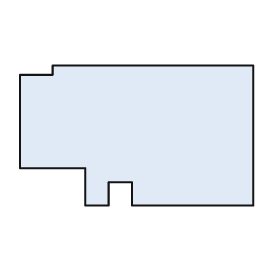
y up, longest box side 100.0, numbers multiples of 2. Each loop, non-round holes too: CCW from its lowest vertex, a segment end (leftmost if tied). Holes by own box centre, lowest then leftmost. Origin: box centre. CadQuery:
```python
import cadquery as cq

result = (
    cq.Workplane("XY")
    .moveTo(-22.0, -30.0)
    .lineTo(-12.0, -30.0)
    .lineTo(-12.0, -20.0)
    .lineTo(-2.0, -20.0)
    .lineTo(-2.0, -30.0)
    .lineTo(50.0, -30.0)
    .lineTo(50.0, 30.0)
    .lineTo(-36.0, 30.0)
    .lineTo(-36.0, 26.0)
    .lineTo(-50.0, 26.0)
    .lineTo(-50.0, -14.0)
    .lineTo(-22.0, -14.0)
    .close()
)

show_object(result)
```